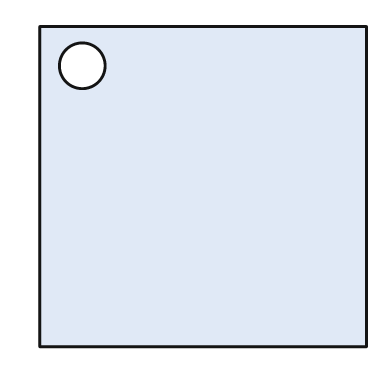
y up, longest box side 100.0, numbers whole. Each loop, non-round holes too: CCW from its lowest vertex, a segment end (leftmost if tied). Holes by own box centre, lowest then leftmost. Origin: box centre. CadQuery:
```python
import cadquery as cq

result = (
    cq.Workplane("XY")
    .moveTo(-50.0, -49.0)
    .lineTo(50.0, -49.0)
    .lineTo(50.0, 49.0)
    .lineTo(-50.0, 49.0)
    .close()
    .moveTo(-37.0, 37.0)
    .circle(7.0)
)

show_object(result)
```